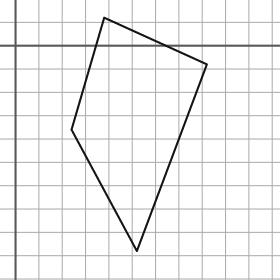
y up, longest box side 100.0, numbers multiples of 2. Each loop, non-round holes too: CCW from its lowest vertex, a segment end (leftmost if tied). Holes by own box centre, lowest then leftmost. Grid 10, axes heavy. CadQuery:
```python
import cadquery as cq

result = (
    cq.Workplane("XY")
    .moveTo(52.0, -88.0)
    .lineTo(82.0, -8.0)
    .lineTo(38.0, 12.0)
    .lineTo(24.0, -36.0)
    .close()
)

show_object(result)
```